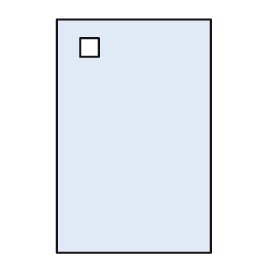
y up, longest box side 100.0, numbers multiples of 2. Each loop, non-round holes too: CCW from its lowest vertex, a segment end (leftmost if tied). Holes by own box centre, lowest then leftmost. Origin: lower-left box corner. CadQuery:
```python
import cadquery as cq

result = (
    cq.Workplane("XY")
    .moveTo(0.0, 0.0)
    .lineTo(66.0, 0.0)
    .lineTo(66.0, 100.0)
    .lineTo(0.0, 100.0)
    .close()
    .moveTo(10.0, 84.0)
    .lineTo(18.0, 84.0)
    .lineTo(18.0, 92.0)
    .lineTo(10.0, 92.0)
    .close()
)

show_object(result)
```